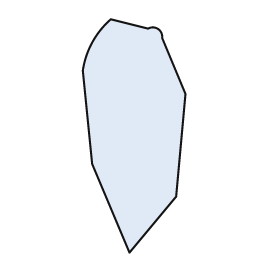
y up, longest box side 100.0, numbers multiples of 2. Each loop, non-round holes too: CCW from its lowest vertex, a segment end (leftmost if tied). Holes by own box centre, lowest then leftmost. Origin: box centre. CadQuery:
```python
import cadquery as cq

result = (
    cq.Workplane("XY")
    .moveTo(-2.0, -50.0)
    .lineTo(18.0, -26.0)
    .lineTo(22.0, 18.0)
    .lineTo(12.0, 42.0)
    .threePointArc((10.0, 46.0), (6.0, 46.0))
    .lineTo(-10.0, 50.0)
    .threePointArc((-18.0, 40.0), (-22.0, 28.0))
    .lineTo(-18.0, -12.0)
    .close()
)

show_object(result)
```